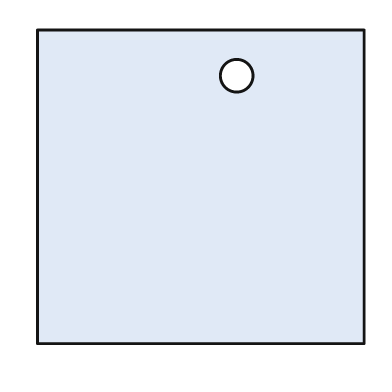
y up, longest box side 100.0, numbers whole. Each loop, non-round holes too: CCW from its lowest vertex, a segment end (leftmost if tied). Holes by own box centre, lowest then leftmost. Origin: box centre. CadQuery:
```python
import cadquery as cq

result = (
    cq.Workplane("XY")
    .moveTo(-50.0, -48.0)
    .lineTo(50.0, -48.0)
    .lineTo(50.0, 48.0)
    .lineTo(-50.0, 48.0)
    .close()
    .moveTo(11.0, 34.0)
    .circle(5.0)
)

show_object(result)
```